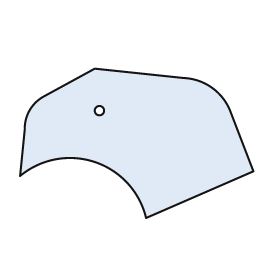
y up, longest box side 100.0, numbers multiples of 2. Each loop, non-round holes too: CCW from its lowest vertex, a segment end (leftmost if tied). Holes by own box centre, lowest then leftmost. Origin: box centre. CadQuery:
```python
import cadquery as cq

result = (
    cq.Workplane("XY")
    .moveTo(4.0, -32.0)
    .lineTo(50.0, -12.0)
    .lineTo(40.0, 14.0)
    .threePointArc((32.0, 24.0), (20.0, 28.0))
    .lineTo(-18.0, 32.0)
    .lineTo(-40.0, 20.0)
    .threePointArc((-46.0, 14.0), (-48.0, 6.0))
    .lineTo(-50.0, -14.0)
    .threePointArc((-18.0, -8.0), (4.0, -32.0))
    .close()
    .moveTo(-16.0, 14.0)
    .circle(2.0)
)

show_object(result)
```